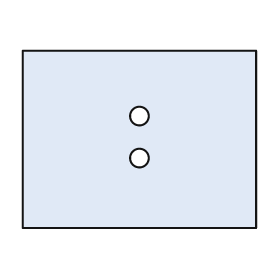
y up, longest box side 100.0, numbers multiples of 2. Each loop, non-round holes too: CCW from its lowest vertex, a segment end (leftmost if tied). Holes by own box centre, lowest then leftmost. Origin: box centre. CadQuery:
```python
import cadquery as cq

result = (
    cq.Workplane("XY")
    .moveTo(-50.0, -38.0)
    .lineTo(50.0, -38.0)
    .lineTo(50.0, 38.0)
    .lineTo(-50.0, 38.0)
    .close()
    .moveTo(0.0, -8.0)
    .circle(4.0)
    .moveTo(0.0, 10.0)
    .circle(4.0)
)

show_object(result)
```